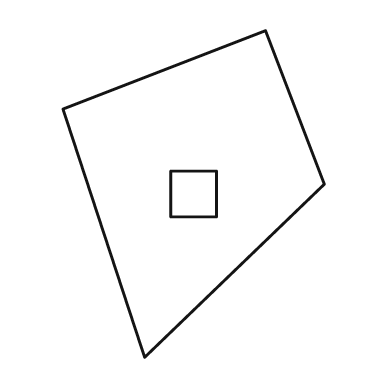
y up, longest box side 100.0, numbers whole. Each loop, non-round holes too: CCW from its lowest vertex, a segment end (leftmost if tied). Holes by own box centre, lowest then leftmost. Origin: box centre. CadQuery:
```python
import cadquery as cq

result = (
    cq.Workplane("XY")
    .moveTo(-15.0, -50.0)
    .lineTo(40.0, 3.0)
    .lineTo(22.0, 50.0)
    .lineTo(-40.0, 26.0)
    .close()
    .moveTo(-7.0, -7.0)
    .lineTo(7.0, -7.0)
    .lineTo(7.0, 7.0)
    .lineTo(-7.0, 7.0)
    .close()
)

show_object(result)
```